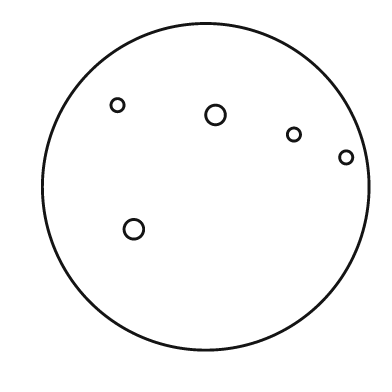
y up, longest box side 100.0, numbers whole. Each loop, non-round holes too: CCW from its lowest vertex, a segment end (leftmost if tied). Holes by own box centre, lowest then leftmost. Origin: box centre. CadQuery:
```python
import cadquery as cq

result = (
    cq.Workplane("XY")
    .moveTo(0.0, 0.0)
    .circle(50.0)
    .moveTo(-22.0, -13.0)
    .circle(3.0)
    .moveTo(43.0, 9.0)
    .circle(2.0)
    .moveTo(27.0, 16.0)
    .circle(2.0)
    .moveTo(3.0, 22.0)
    .circle(3.0)
    .moveTo(-27.0, 25.0)
    .circle(2.0)
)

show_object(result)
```